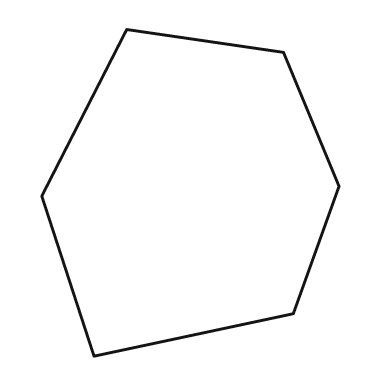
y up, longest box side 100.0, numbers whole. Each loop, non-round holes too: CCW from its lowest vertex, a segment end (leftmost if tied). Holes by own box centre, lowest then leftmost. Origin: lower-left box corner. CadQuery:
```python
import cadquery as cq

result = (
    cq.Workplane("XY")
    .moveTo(16.0, 0.0)
    .lineTo(77.0, 13.0)
    .lineTo(91.0, 52.0)
    .lineTo(74.0, 93.0)
    .lineTo(26.0, 100.0)
    .lineTo(0.0, 49.0)
    .close()
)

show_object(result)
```